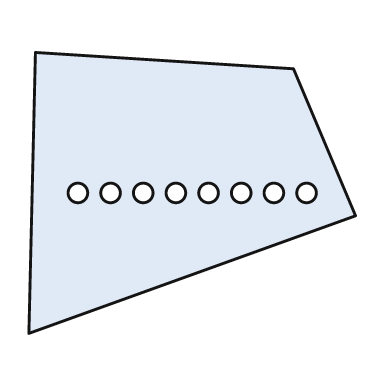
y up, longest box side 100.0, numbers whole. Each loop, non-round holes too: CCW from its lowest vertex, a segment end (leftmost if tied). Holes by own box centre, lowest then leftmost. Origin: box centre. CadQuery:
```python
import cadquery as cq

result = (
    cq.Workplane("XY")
    .moveTo(-50.0, -43.0)
    .lineTo(50.0, -7.0)
    .lineTo(31.0, 38.0)
    .lineTo(-48.0, 43.0)
    .close()
    .moveTo(-35.0, 0.0)
    .circle(3.0)
    .moveTo(-25.0, 0.0)
    .circle(3.0)
    .moveTo(-15.0, 0.0)
    .circle(3.0)
    .moveTo(-5.0, 0.0)
    .circle(3.0)
    .moveTo(5.0, 0.0)
    .circle(3.0)
    .moveTo(15.0, 0.0)
    .circle(3.0)
    .moveTo(25.0, 0.0)
    .circle(3.0)
    .moveTo(35.0, 0.0)
    .circle(3.0)
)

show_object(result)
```